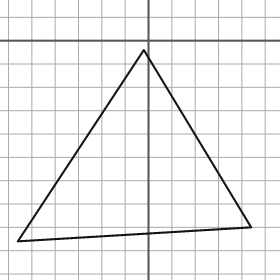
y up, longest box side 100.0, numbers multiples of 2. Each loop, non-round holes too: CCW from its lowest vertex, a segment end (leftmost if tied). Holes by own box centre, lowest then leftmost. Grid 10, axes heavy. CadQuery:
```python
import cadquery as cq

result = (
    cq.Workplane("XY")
    .moveTo(-56.0, -86.0)
    .lineTo(44.0, -80.0)
    .lineTo(-2.0, -4.0)
    .close()
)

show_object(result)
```